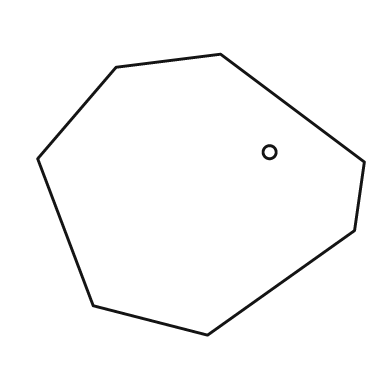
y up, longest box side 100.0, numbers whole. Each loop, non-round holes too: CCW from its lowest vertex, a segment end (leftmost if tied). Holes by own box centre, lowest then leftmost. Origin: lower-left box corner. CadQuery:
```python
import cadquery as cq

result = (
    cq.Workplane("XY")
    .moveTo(52.0, 0.0)
    .lineTo(97.0, 32.0)
    .lineTo(100.0, 53.0)
    .lineTo(56.0, 86.0)
    .lineTo(24.0, 82.0)
    .lineTo(0.0, 54.0)
    .lineTo(17.0, 9.0)
    .close()
    .moveTo(71.0, 56.0)
    .circle(2.0)
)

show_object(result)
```